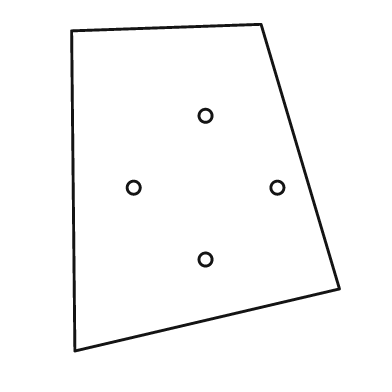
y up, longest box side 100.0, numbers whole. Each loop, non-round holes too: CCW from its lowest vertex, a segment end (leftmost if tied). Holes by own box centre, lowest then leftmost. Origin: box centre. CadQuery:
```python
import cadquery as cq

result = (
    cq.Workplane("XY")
    .moveTo(-40.0, -50.0)
    .lineTo(41.0, -31.0)
    .lineTo(17.0, 50.0)
    .lineTo(-41.0, 48.0)
    .close()
    .moveTo(0.0, -22.0)
    .circle(2.0)
    .moveTo(-22.0, 0.0)
    .circle(2.0)
    .moveTo(22.0, 0.0)
    .circle(2.0)
    .moveTo(0.0, 22.0)
    .circle(2.0)
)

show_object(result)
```